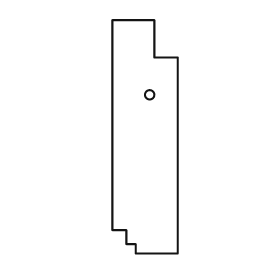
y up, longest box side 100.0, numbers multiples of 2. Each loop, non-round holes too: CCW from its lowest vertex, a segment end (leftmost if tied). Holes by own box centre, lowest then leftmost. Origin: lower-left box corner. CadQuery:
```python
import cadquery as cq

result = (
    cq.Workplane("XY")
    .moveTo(10.0, 0.0)
    .lineTo(28.0, 0.0)
    .lineTo(28.0, 84.0)
    .lineTo(18.0, 84.0)
    .lineTo(18.0, 100.0)
    .lineTo(0.0, 100.0)
    .lineTo(0.0, 10.0)
    .lineTo(6.0, 10.0)
    .lineTo(6.0, 4.0)
    .lineTo(10.0, 4.0)
    .close()
    .moveTo(16.0, 68.0)
    .circle(2.0)
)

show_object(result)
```